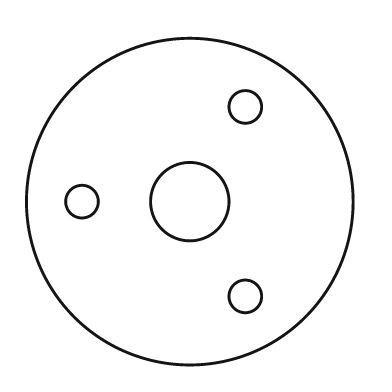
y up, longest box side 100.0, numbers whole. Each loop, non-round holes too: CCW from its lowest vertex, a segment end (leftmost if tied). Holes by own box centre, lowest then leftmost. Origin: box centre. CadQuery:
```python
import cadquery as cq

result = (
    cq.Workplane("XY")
    .moveTo(0.0, 0.0)
    .circle(50.0)
    .moveTo(17.0, -29.0)
    .circle(5.0)
    .moveTo(-33.0, 0.0)
    .circle(5.0)
    .moveTo(0.0, 0.0)
    .circle(12.0)
    .moveTo(17.0, 29.0)
    .circle(5.0)
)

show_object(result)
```